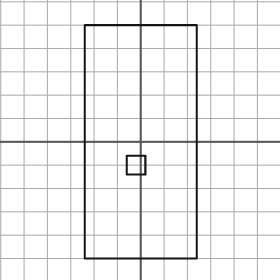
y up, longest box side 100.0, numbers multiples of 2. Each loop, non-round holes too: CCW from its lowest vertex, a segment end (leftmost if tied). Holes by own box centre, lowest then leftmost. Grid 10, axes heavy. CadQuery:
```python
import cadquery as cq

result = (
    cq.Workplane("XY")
    .moveTo(-24.0, -50.0)
    .lineTo(24.0, -50.0)
    .lineTo(24.0, 50.0)
    .lineTo(-24.0, 50.0)
    .close()
    .moveTo(-6.0, -14.0)
    .lineTo(2.0, -14.0)
    .lineTo(2.0, -6.0)
    .lineTo(-6.0, -6.0)
    .close()
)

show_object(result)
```